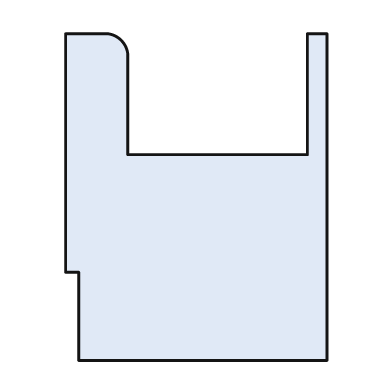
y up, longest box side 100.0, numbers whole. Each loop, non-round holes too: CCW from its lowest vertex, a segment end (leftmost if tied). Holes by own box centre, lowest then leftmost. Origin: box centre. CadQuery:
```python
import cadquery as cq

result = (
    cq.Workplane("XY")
    .moveTo(-36.0, -50.0)
    .lineTo(40.0, -50.0)
    .lineTo(40.0, 50.0)
    .lineTo(34.0, 50.0)
    .lineTo(34.0, 13.0)
    .lineTo(-21.0, 13.0)
    .lineTo(-21.0, 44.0)
    .threePointArc((-23.0, 48.0), (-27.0, 50.0))
    .lineTo(-40.0, 50.0)
    .lineTo(-40.0, -23.0)
    .lineTo(-36.0, -23.0)
    .close()
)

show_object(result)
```